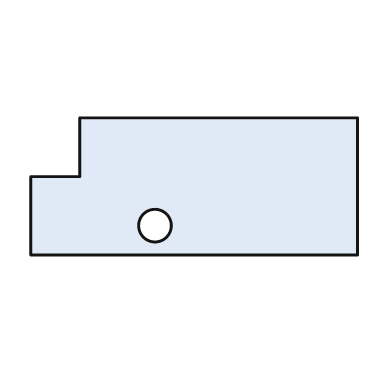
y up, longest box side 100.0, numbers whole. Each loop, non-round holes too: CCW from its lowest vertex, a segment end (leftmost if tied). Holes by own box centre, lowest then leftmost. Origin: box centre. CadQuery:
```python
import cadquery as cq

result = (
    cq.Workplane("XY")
    .moveTo(-50.0, -21.0)
    .lineTo(50.0, -21.0)
    .lineTo(50.0, 21.0)
    .lineTo(-35.0, 21.0)
    .lineTo(-35.0, 3.0)
    .lineTo(-50.0, 3.0)
    .close()
    .moveTo(-12.0, -12.0)
    .circle(5.0)
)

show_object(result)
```